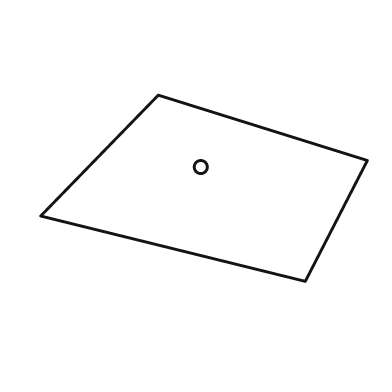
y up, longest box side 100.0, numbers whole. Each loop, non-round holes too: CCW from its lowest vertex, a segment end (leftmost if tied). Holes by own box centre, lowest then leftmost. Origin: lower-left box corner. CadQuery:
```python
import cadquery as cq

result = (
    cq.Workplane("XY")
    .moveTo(81.0, 0.0)
    .lineTo(100.0, 37.0)
    .lineTo(36.0, 57.0)
    .lineTo(0.0, 20.0)
    .close()
    .moveTo(49.0, 35.0)
    .circle(2.0)
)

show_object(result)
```